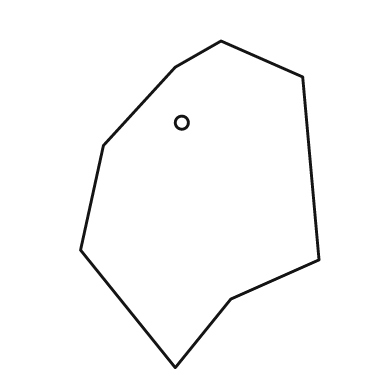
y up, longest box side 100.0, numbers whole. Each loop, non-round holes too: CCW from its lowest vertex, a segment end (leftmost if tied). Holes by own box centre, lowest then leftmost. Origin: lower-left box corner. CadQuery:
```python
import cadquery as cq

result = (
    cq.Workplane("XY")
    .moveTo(29.0, 0.0)
    .lineTo(46.0, 21.0)
    .lineTo(73.0, 33.0)
    .lineTo(68.0, 89.0)
    .lineTo(43.0, 100.0)
    .lineTo(29.0, 92.0)
    .lineTo(7.0, 68.0)
    .lineTo(0.0, 36.0)
    .close()
    .moveTo(31.0, 75.0)
    .circle(2.0)
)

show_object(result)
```